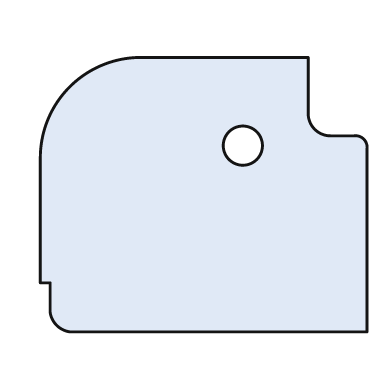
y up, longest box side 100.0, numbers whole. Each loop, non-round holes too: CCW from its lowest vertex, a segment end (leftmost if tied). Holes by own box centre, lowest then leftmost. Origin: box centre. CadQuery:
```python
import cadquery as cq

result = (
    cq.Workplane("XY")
    .moveTo(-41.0, -42.0)
    .lineTo(50.0, -42.0)
    .lineTo(50.0, 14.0)
    .threePointArc((49.0, 17.0), (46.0, 18.0))
    .lineTo(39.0, 18.0)
    .threePointArc((34.0, 20.0), (32.0, 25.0))
    .lineTo(32.0, 42.0)
    .lineTo(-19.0, 42.0)
    .threePointArc((-41.0, 33.0), (-50.0, 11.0))
    .lineTo(-50.0, -27.0)
    .lineTo(-47.0, -27.0)
    .lineTo(-47.0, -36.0)
    .threePointArc((-45.0, -40.0), (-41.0, -42.0))
    .close()
    .moveTo(12.0, 15.0)
    .circle(6.0)
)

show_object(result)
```